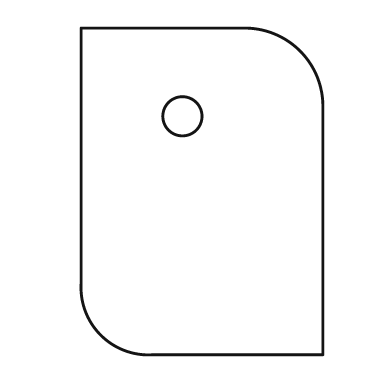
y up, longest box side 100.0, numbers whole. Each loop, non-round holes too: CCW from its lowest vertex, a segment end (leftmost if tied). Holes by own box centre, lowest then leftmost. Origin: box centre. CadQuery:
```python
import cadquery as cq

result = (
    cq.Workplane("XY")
    .moveTo(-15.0, -50.0)
    .lineTo(37.0, -50.0)
    .lineTo(37.0, 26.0)
    .threePointArc((30.0, 43.0), (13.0, 50.0))
    .lineTo(-37.0, 50.0)
    .lineTo(-37.0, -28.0)
    .threePointArc((-31.0, -44.0), (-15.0, -50.0))
    .close()
    .moveTo(-6.0, 23.0)
    .circle(6.0)
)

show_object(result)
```